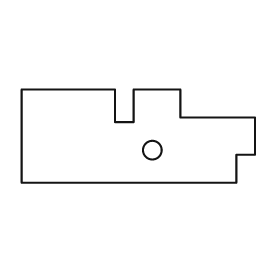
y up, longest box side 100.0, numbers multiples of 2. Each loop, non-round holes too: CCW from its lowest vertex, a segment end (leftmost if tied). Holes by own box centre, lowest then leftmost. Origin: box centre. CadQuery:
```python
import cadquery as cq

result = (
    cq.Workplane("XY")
    .moveTo(-50.0, -20.0)
    .lineTo(42.0, -20.0)
    .lineTo(42.0, -8.0)
    .lineTo(50.0, -8.0)
    .lineTo(50.0, 8.0)
    .lineTo(18.0, 8.0)
    .lineTo(18.0, 20.0)
    .lineTo(-2.0, 20.0)
    .lineTo(-2.0, 6.0)
    .lineTo(-10.0, 6.0)
    .lineTo(-10.0, 20.0)
    .lineTo(-50.0, 20.0)
    .close()
    .moveTo(6.0, -6.0)
    .circle(4.0)
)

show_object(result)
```